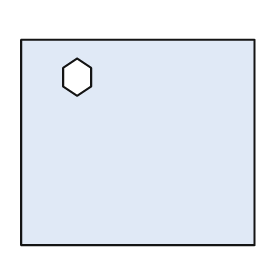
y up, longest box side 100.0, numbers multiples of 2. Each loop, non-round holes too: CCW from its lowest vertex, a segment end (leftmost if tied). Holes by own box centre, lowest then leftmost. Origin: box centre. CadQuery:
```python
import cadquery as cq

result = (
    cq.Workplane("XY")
    .moveTo(-50.0, -44.0)
    .lineTo(50.0, -44.0)
    .lineTo(50.0, 44.0)
    .lineTo(-50.0, 44.0)
    .close()
    .moveTo(-26.0, 20.0)
    .lineTo(-20.0, 24.0)
    .lineTo(-20.0, 32.0)
    .lineTo(-26.0, 36.0)
    .lineTo(-32.0, 32.0)
    .lineTo(-32.0, 24.0)
    .close()
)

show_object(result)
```